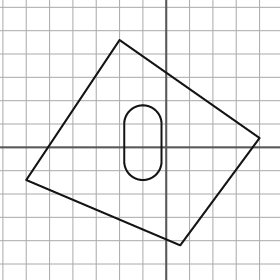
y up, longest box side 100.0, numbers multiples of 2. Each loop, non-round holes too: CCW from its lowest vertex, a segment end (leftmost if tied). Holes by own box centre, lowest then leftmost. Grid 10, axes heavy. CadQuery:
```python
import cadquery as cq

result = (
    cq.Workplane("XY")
    .moveTo(6.0, -42.0)
    .lineTo(40.0, 4.0)
    .lineTo(-20.0, 46.0)
    .lineTo(-60.0, -14.0)
    .close()
    .moveTo(-18.0, -6.0)
    .threePointArc((-10.0, -14.0), (-2.0, -6.0))
    .lineTo(-2.0, 10.0)
    .threePointArc((-10.0, 18.0), (-18.0, 10.0))
    .close()
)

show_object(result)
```